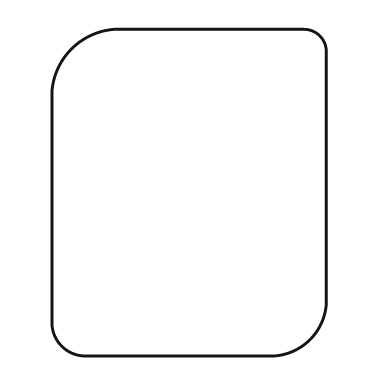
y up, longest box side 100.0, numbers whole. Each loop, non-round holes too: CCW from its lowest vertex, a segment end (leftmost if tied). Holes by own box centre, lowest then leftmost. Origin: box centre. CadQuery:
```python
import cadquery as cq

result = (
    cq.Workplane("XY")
    .moveTo(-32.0, -50.0)
    .lineTo(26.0, -50.0)
    .threePointArc((37.0, -45.0), (42.0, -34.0))
    .lineTo(42.0, 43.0)
    .threePointArc((40.0, 48.0), (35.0, 50.0))
    .lineTo(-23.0, 50.0)
    .threePointArc((-36.0, 44.0), (-42.0, 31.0))
    .lineTo(-42.0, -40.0)
    .threePointArc((-39.0, -47.0), (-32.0, -50.0))
    .close()
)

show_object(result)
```